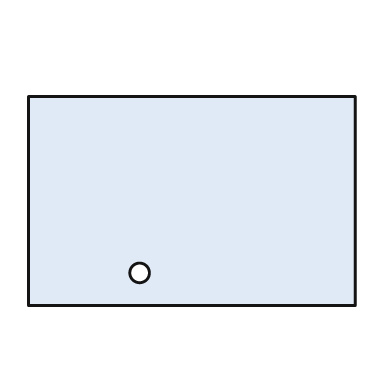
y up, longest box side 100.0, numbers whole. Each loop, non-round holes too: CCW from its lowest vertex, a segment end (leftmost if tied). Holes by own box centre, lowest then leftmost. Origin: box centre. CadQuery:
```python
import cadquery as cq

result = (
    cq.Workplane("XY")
    .moveTo(-50.0, -32.0)
    .lineTo(50.0, -32.0)
    .lineTo(50.0, 32.0)
    .lineTo(-50.0, 32.0)
    .close()
    .moveTo(-16.0, -22.0)
    .circle(3.0)
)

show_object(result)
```